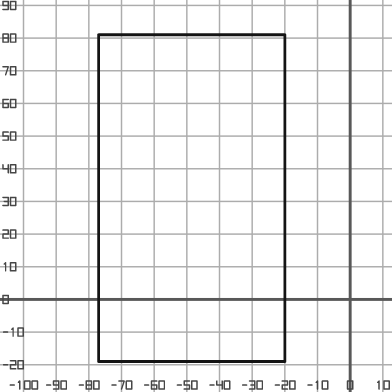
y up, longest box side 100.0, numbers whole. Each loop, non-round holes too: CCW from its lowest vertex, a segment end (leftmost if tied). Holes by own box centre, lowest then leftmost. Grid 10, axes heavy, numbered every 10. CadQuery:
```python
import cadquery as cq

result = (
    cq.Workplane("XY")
    .moveTo(-77.0, -19.0)
    .lineTo(-20.0, -19.0)
    .lineTo(-20.0, 81.0)
    .lineTo(-77.0, 81.0)
    .close()
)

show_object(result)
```